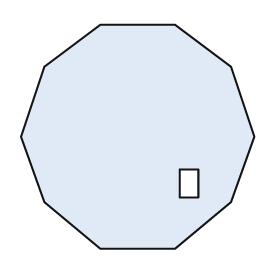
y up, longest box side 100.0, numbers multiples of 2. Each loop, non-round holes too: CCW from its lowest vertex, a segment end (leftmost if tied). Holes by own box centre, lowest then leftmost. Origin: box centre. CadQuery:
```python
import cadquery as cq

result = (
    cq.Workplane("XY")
    .moveTo(-16.0, -48.0)
    .lineTo(16.0, -48.0)
    .lineTo(40.0, -28.0)
    .lineTo(50.0, 0.0)
    .lineTo(40.0, 30.0)
    .lineTo(16.0, 48.0)
    .lineTo(-16.0, 48.0)
    .lineTo(-40.0, 30.0)
    .lineTo(-50.0, 0.0)
    .lineTo(-40.0, -28.0)
    .close()
    .moveTo(18.0, -26.0)
    .lineTo(26.0, -26.0)
    .lineTo(26.0, -14.0)
    .lineTo(18.0, -14.0)
    .close()
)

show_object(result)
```